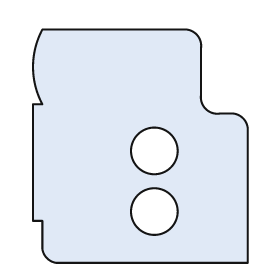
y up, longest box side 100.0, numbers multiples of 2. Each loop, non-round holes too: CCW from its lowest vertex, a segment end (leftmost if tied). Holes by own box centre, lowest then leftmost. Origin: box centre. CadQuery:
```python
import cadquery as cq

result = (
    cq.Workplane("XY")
    .moveTo(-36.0, -50.0)
    .lineTo(46.0, -50.0)
    .lineTo(46.0, 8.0)
    .threePointArc((44.0, 12.0), (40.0, 14.0))
    .lineTo(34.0, 14.0)
    .threePointArc((28.0, 16.0), (26.0, 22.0))
    .lineTo(26.0, 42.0)
    .threePointArc((24.0, 48.0), (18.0, 50.0))
    .lineTo(-42.0, 50.0)
    .threePointArc((-46.0, 34.0), (-42.0, 18.0))
    .lineTo(-46.0, 18.0)
    .lineTo(-46.0, -32.0)
    .lineTo(-42.0, -32.0)
    .lineTo(-42.0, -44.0)
    .threePointArc((-40.0, -48.0), (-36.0, -50.0))
    .close()
    .moveTo(6.0, -28.0)
    .circle(10.0)
    .moveTo(6.0, -2.0)
    .circle(10.0)
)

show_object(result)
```